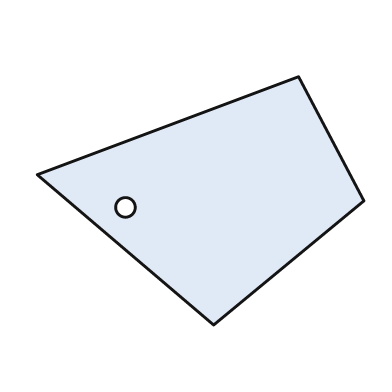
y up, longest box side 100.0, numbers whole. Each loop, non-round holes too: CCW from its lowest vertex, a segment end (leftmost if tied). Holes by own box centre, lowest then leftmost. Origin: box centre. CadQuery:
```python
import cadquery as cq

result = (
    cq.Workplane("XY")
    .moveTo(4.0, -38.0)
    .lineTo(50.0, 0.0)
    .lineTo(30.0, 38.0)
    .lineTo(-50.0, 8.0)
    .close()
    .moveTo(-23.0, -2.0)
    .circle(3.0)
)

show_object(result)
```